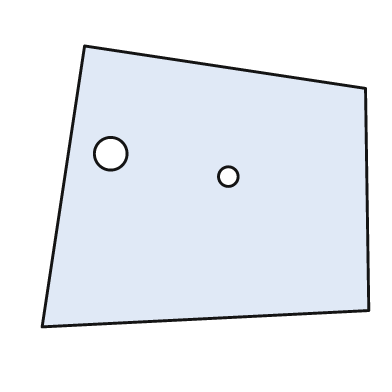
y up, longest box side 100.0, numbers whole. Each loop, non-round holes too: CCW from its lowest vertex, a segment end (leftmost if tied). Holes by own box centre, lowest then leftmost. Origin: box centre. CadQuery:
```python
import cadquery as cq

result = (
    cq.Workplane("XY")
    .moveTo(-50.0, -43.0)
    .lineTo(50.0, -38.0)
    .lineTo(49.0, 30.0)
    .lineTo(-37.0, 43.0)
    .close()
    .moveTo(7.0, 3.0)
    .circle(3.0)
    .moveTo(-29.0, 10.0)
    .circle(5.0)
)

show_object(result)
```